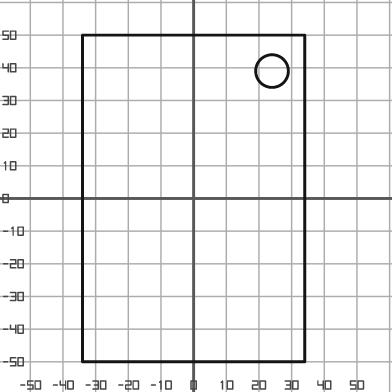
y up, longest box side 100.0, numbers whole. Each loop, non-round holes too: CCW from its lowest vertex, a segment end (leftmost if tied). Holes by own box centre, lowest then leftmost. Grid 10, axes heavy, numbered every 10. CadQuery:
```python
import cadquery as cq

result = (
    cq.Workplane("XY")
    .moveTo(-34.0, -50.0)
    .lineTo(34.0, -50.0)
    .lineTo(34.0, 50.0)
    .lineTo(-34.0, 50.0)
    .close()
    .moveTo(24.0, 39.0)
    .circle(5.0)
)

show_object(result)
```